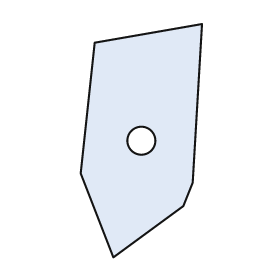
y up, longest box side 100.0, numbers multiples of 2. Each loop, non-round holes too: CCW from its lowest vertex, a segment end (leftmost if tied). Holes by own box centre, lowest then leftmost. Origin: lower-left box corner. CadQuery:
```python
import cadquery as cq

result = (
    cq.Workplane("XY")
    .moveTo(14.0, 0.0)
    .lineTo(44.0, 22.0)
    .lineTo(48.0, 32.0)
    .lineTo(52.0, 100.0)
    .lineTo(6.0, 92.0)
    .lineTo(0.0, 36.0)
    .close()
    .moveTo(26.0, 50.0)
    .circle(6.0)
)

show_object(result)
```